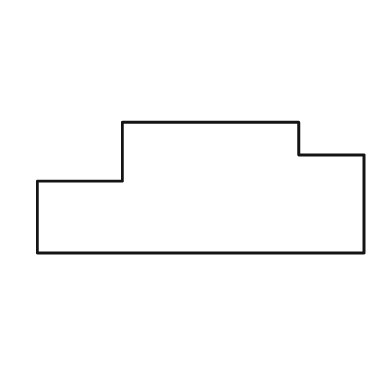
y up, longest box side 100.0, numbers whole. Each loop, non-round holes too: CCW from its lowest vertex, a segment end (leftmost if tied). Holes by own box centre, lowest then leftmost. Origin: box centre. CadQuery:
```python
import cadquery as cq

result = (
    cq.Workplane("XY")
    .moveTo(-50.0, -20.0)
    .lineTo(50.0, -20.0)
    .lineTo(50.0, 10.0)
    .lineTo(30.0, 10.0)
    .lineTo(30.0, 20.0)
    .lineTo(-24.0, 20.0)
    .lineTo(-24.0, 2.0)
    .lineTo(-50.0, 2.0)
    .close()
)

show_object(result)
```